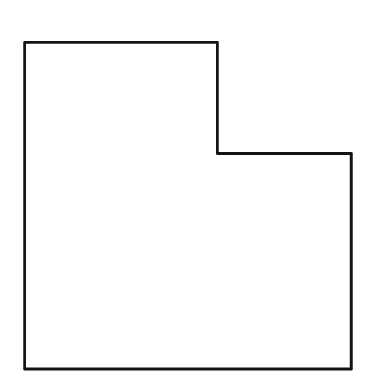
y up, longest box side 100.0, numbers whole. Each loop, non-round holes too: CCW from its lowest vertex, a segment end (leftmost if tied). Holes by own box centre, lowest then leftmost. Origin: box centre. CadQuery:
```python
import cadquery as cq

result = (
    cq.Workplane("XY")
    .moveTo(-50.0, -50.0)
    .lineTo(50.0, -50.0)
    .lineTo(50.0, 16.0)
    .lineTo(9.0, 16.0)
    .lineTo(9.0, 50.0)
    .lineTo(-50.0, 50.0)
    .close()
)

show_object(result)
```